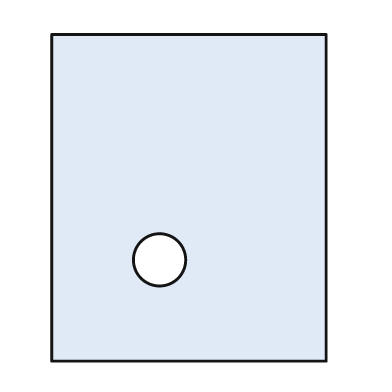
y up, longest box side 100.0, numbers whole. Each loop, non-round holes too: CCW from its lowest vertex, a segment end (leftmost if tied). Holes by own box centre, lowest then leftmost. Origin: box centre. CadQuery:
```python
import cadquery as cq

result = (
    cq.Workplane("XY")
    .moveTo(-42.0, -50.0)
    .lineTo(42.0, -50.0)
    .lineTo(42.0, 50.0)
    .lineTo(-42.0, 50.0)
    .close()
    .moveTo(-9.0, -19.0)
    .circle(8.0)
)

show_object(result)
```